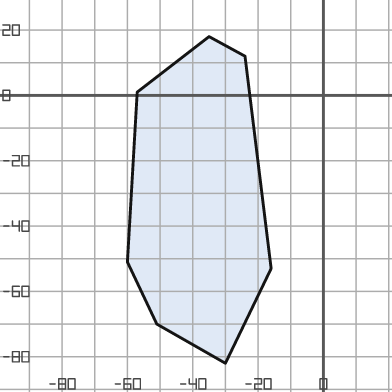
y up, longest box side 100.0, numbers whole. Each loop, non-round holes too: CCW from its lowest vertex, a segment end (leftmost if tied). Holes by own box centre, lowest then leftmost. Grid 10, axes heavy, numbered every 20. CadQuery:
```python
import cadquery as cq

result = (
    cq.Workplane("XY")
    .moveTo(-30.0, -82.0)
    .lineTo(-16.0, -53.0)
    .lineTo(-24.0, 12.0)
    .lineTo(-35.0, 18.0)
    .lineTo(-57.0, 1.0)
    .lineTo(-60.0, -51.0)
    .lineTo(-51.0, -70.0)
    .close()
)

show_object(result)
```